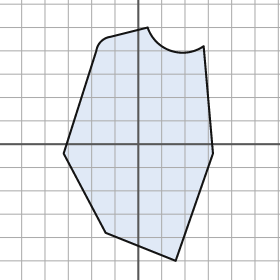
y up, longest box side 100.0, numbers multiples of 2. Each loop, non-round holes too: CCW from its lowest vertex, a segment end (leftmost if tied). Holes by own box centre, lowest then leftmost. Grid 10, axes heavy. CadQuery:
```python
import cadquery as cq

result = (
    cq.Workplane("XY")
    .moveTo(16.0, -50.0)
    .lineTo(32.0, -4.0)
    .lineTo(28.0, 42.0)
    .threePointArc((14.0, 40.0), (4.0, 50.0))
    .lineTo(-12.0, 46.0)
    .threePointArc((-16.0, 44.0), (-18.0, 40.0))
    .lineTo(-32.0, -4.0)
    .lineTo(-14.0, -38.0)
    .close()
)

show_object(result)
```